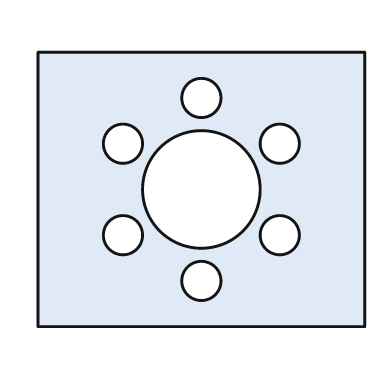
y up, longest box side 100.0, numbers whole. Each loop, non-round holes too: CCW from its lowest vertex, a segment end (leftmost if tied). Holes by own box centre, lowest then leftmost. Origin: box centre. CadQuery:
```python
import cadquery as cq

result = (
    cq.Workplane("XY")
    .moveTo(-50.0, -42.0)
    .lineTo(50.0, -42.0)
    .lineTo(50.0, 42.0)
    .lineTo(-50.0, 42.0)
    .close()
    .moveTo(0.0, -28.0)
    .circle(6.0)
    .moveTo(-24.0, -14.0)
    .circle(6.0)
    .moveTo(24.0, -14.0)
    .circle(6.0)
    .moveTo(0.0, 0.0)
    .circle(18.0)
    .moveTo(-24.0, 14.0)
    .circle(6.0)
    .moveTo(24.0, 14.0)
    .circle(6.0)
    .moveTo(0.0, 28.0)
    .circle(6.0)
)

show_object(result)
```